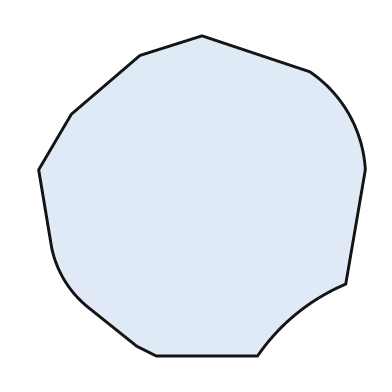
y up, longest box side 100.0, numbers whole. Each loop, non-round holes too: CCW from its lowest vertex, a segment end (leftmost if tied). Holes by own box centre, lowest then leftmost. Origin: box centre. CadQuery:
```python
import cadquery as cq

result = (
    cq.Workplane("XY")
    .moveTo(-14.0, -49.0)
    .lineTo(17.0, -49.0)
    .threePointArc((29.0, -36.0), (44.0, -27.0))
    .lineTo(50.0, 8.0)
    .threePointArc((45.0, 25.0), (33.0, 38.0))
    .lineTo(0.0, 49.0)
    .lineTo(-19.0, 43.0)
    .lineTo(-40.0, 25.0)
    .lineTo(-50.0, 8.0)
    .lineTo(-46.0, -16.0)
    .threePointArc((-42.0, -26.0), (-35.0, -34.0))
    .lineTo(-20.0, -46.0)
    .close()
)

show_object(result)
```